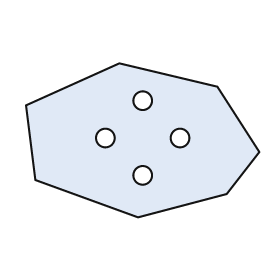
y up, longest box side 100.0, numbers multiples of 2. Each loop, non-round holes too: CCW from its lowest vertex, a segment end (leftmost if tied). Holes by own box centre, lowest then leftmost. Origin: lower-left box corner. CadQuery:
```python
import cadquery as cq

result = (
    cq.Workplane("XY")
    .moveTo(48.0, 0.0)
    .lineTo(86.0, 10.0)
    .lineTo(100.0, 28.0)
    .lineTo(82.0, 56.0)
    .lineTo(40.0, 66.0)
    .lineTo(0.0, 48.0)
    .lineTo(4.0, 16.0)
    .close()
    .moveTo(50.0, 18.0)
    .circle(4.0)
    .moveTo(34.0, 34.0)
    .circle(4.0)
    .moveTo(66.0, 34.0)
    .circle(4.0)
    .moveTo(50.0, 50.0)
    .circle(4.0)
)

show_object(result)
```